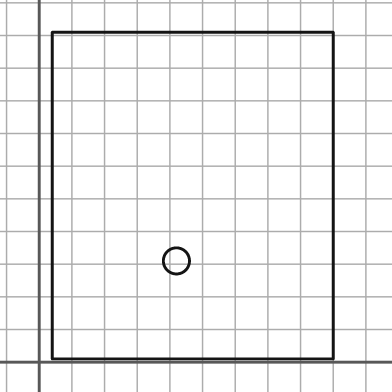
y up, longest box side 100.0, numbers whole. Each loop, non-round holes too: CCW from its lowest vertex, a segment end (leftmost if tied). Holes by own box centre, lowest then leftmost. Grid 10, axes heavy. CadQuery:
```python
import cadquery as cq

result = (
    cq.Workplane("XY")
    .moveTo(4.0, 1.0)
    .lineTo(90.0, 1.0)
    .lineTo(90.0, 101.0)
    .lineTo(4.0, 101.0)
    .close()
    .moveTo(42.0, 31.0)
    .circle(4.0)
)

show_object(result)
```